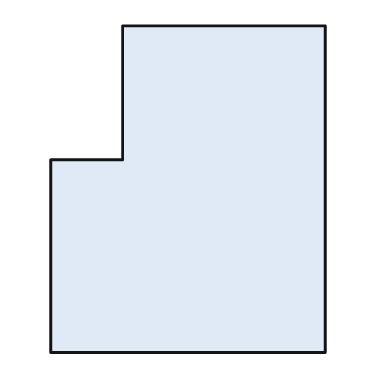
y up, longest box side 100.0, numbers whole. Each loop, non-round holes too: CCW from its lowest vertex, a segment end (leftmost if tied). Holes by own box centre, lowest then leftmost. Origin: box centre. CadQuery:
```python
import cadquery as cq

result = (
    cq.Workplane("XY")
    .moveTo(-42.0, -50.0)
    .lineTo(42.0, -50.0)
    .lineTo(42.0, 50.0)
    .lineTo(-20.0, 50.0)
    .lineTo(-20.0, 9.0)
    .lineTo(-42.0, 9.0)
    .close()
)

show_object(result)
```